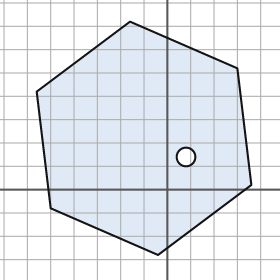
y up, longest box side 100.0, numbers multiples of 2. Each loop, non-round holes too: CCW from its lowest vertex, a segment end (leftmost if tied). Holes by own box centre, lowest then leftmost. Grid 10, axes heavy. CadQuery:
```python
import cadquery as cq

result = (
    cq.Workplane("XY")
    .moveTo(-4.0, -28.0)
    .lineTo(36.0, 2.0)
    .lineTo(30.0, 52.0)
    .lineTo(-16.0, 72.0)
    .lineTo(-56.0, 42.0)
    .lineTo(-50.0, -8.0)
    .close()
    .moveTo(8.0, 14.0)
    .circle(4.0)
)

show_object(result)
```